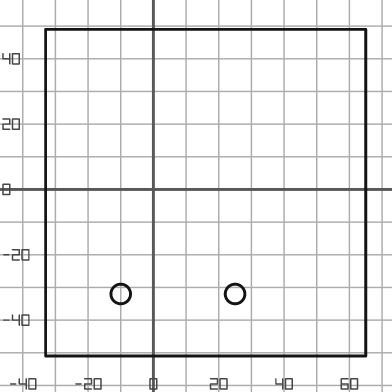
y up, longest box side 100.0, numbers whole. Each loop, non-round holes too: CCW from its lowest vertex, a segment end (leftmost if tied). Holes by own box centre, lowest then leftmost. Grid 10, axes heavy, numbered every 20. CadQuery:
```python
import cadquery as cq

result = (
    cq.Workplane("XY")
    .moveTo(-33.0, -51.0)
    .lineTo(65.0, -51.0)
    .lineTo(65.0, 49.0)
    .lineTo(-33.0, 49.0)
    .close()
    .moveTo(-10.0, -32.0)
    .circle(3.0)
    .moveTo(25.0, -32.0)
    .circle(3.0)
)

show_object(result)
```